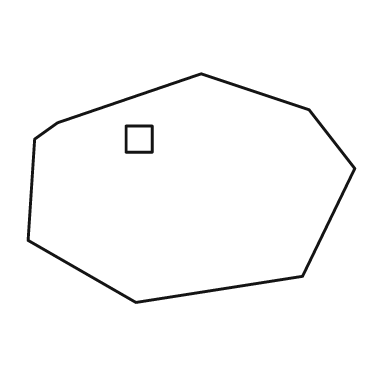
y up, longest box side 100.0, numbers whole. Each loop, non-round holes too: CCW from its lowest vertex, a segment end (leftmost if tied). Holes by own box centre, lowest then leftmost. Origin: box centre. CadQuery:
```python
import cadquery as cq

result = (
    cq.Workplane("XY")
    .moveTo(-17.0, -35.0)
    .lineTo(34.0, -27.0)
    .lineTo(50.0, 6.0)
    .lineTo(36.0, 24.0)
    .lineTo(3.0, 35.0)
    .lineTo(-41.0, 20.0)
    .lineTo(-48.0, 15.0)
    .lineTo(-50.0, -16.0)
    .close()
    .moveTo(-20.0, 11.0)
    .lineTo(-12.0, 11.0)
    .lineTo(-12.0, 19.0)
    .lineTo(-20.0, 19.0)
    .close()
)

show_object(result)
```